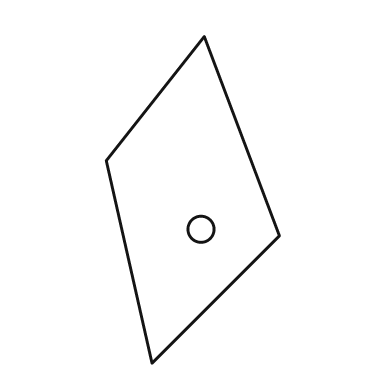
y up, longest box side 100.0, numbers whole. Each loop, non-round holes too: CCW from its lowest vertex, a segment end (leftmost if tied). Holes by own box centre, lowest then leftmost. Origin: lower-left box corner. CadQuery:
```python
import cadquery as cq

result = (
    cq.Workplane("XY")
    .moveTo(14.0, 0.0)
    .lineTo(53.0, 39.0)
    .lineTo(30.0, 100.0)
    .lineTo(0.0, 62.0)
    .close()
    .moveTo(29.0, 41.0)
    .circle(4.0)
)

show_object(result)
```